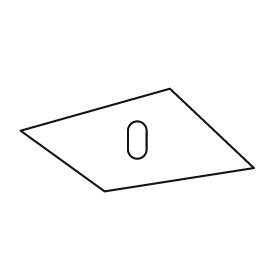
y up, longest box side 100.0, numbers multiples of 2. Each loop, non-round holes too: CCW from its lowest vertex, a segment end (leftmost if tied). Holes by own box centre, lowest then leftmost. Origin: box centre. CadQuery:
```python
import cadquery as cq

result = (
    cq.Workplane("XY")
    .moveTo(-14.0, -22.0)
    .lineTo(50.0, -12.0)
    .lineTo(14.0, 22.0)
    .lineTo(-50.0, 4.0)
    .close()
    .moveTo(-4.0, -4.0)
    .threePointArc((0.0, -8.0), (4.0, -4.0))
    .lineTo(4.0, 4.0)
    .threePointArc((0.0, 8.0), (-4.0, 4.0))
    .close()
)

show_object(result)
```